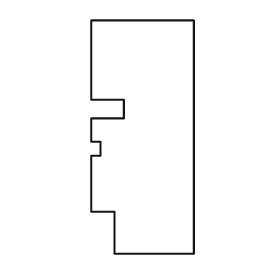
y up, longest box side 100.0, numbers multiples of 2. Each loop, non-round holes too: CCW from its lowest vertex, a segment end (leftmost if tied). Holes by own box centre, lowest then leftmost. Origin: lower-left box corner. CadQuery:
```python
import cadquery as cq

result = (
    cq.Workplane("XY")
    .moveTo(10.0, 0.0)
    .lineTo(44.0, 0.0)
    .lineTo(44.0, 100.0)
    .lineTo(0.0, 100.0)
    .lineTo(0.0, 66.0)
    .lineTo(14.0, 66.0)
    .lineTo(14.0, 58.0)
    .lineTo(0.0, 58.0)
    .lineTo(0.0, 48.0)
    .lineTo(4.0, 48.0)
    .lineTo(4.0, 42.0)
    .lineTo(0.0, 42.0)
    .lineTo(0.0, 18.0)
    .lineTo(10.0, 18.0)
    .close()
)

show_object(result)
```